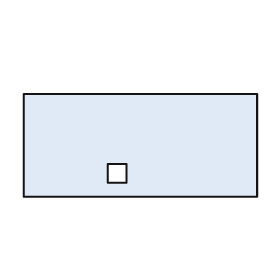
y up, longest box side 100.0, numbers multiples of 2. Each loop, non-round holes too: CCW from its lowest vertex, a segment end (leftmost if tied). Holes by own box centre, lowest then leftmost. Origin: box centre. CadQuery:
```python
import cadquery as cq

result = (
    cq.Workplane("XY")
    .moveTo(-50.0, -22.0)
    .lineTo(50.0, -22.0)
    .lineTo(50.0, 22.0)
    .lineTo(-50.0, 22.0)
    .close()
    .moveTo(-14.0, -16.0)
    .lineTo(-6.0, -16.0)
    .lineTo(-6.0, -8.0)
    .lineTo(-14.0, -8.0)
    .close()
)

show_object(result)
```